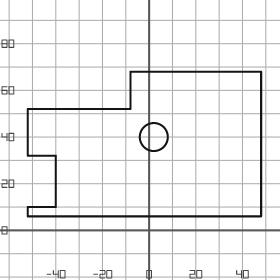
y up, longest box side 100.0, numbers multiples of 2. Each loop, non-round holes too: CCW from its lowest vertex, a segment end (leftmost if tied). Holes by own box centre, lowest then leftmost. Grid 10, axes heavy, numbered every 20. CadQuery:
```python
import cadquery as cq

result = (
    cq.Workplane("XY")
    .moveTo(-52.0, 6.0)
    .lineTo(48.0, 6.0)
    .lineTo(48.0, 68.0)
    .lineTo(-8.0, 68.0)
    .lineTo(-8.0, 52.0)
    .lineTo(-52.0, 52.0)
    .lineTo(-52.0, 32.0)
    .lineTo(-40.0, 32.0)
    .lineTo(-40.0, 10.0)
    .lineTo(-52.0, 10.0)
    .close()
    .moveTo(2.0, 40.0)
    .circle(6.0)
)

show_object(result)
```